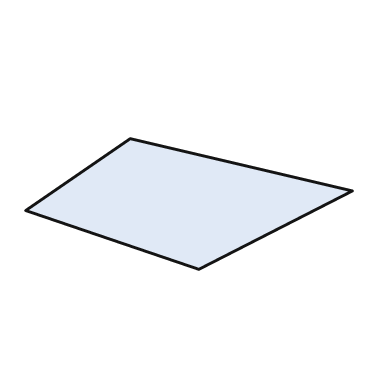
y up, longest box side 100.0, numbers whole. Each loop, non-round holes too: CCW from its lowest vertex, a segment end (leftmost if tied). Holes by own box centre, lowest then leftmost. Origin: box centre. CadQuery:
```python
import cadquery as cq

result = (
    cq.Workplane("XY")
    .moveTo(3.0, -20.0)
    .lineTo(50.0, 4.0)
    .lineTo(-18.0, 20.0)
    .lineTo(-50.0, -2.0)
    .close()
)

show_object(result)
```